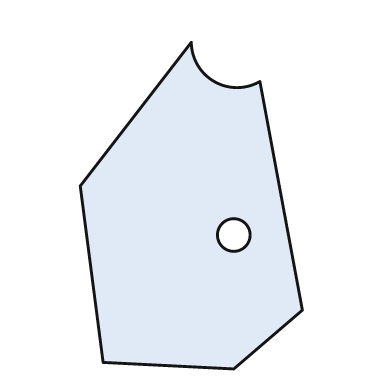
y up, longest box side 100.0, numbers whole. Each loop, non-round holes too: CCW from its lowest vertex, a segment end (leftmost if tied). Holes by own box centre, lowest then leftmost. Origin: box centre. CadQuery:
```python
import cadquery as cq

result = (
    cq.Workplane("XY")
    .moveTo(13.0, -50.0)
    .lineTo(34.0, -32.0)
    .lineTo(21.0, 38.0)
    .threePointArc((7.0, 38.0), (0.0, 50.0))
    .lineTo(-34.0, 6.0)
    .lineTo(-27.0, -48.0)
    .close()
    .moveTo(13.0, -9.0)
    .circle(5.0)
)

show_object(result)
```